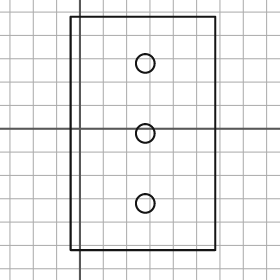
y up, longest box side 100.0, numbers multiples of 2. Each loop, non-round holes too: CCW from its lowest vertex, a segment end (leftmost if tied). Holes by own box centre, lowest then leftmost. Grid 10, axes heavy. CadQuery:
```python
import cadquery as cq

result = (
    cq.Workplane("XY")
    .moveTo(-4.0, -52.0)
    .lineTo(58.0, -52.0)
    .lineTo(58.0, 48.0)
    .lineTo(-4.0, 48.0)
    .close()
    .moveTo(28.0, -32.0)
    .circle(4.0)
    .moveTo(28.0, -2.0)
    .circle(4.0)
    .moveTo(28.0, 28.0)
    .circle(4.0)
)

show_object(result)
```